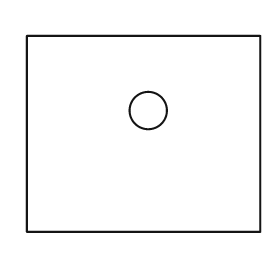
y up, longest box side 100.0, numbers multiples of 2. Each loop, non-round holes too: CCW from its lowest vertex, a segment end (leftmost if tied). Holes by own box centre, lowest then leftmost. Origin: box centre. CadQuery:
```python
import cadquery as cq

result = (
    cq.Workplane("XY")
    .moveTo(-50.0, -42.0)
    .lineTo(50.0, -42.0)
    .lineTo(50.0, 42.0)
    .lineTo(-50.0, 42.0)
    .close()
    .moveTo(2.0, 10.0)
    .circle(8.0)
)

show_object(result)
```